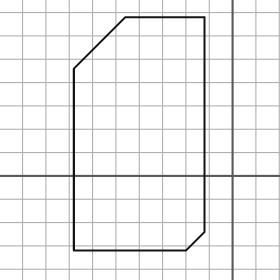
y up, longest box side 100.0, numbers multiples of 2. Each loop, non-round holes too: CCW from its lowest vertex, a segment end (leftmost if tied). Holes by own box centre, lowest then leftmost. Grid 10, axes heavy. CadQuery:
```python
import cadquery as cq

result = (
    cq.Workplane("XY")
    .moveTo(-68.0, -32.0)
    .lineTo(-20.0, -32.0)
    .lineTo(-12.0, -24.0)
    .lineTo(-12.0, 68.0)
    .lineTo(-46.0, 68.0)
    .lineTo(-68.0, 46.0)
    .close()
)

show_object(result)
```